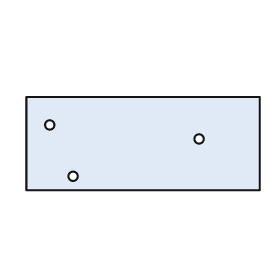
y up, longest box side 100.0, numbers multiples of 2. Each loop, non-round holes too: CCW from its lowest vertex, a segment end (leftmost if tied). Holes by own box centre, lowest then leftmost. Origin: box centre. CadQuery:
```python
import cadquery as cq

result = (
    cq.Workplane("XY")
    .moveTo(-50.0, -20.0)
    .lineTo(50.0, -20.0)
    .lineTo(50.0, 20.0)
    .lineTo(-50.0, 20.0)
    .close()
    .moveTo(-30.0, -14.0)
    .circle(2.0)
    .moveTo(24.0, 2.0)
    .circle(2.0)
    .moveTo(-40.0, 8.0)
    .circle(2.0)
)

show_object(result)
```